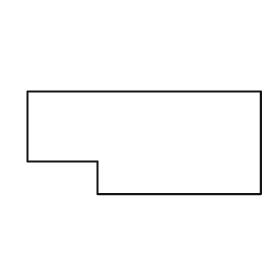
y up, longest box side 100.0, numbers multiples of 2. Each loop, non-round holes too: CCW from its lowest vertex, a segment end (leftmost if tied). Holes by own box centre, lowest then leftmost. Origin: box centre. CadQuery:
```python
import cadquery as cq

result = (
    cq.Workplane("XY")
    .moveTo(-20.0, -22.0)
    .lineTo(50.0, -22.0)
    .lineTo(50.0, 22.0)
    .lineTo(-50.0, 22.0)
    .lineTo(-50.0, -8.0)
    .lineTo(-20.0, -8.0)
    .close()
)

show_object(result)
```